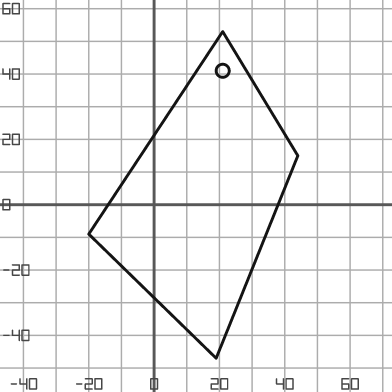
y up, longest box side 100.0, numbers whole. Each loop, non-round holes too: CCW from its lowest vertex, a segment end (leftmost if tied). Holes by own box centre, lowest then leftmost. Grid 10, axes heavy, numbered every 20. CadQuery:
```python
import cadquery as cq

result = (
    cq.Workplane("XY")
    .moveTo(19.0, -47.0)
    .lineTo(44.0, 15.0)
    .lineTo(21.0, 53.0)
    .lineTo(-20.0, -9.0)
    .close()
    .moveTo(21.0, 41.0)
    .circle(2.0)
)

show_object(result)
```